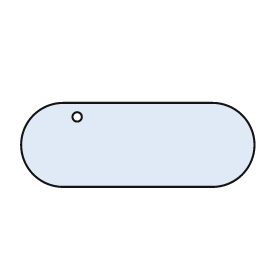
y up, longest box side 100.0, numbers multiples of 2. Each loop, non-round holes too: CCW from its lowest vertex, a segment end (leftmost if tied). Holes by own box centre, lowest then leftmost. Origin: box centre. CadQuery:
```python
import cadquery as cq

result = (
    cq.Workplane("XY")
    .moveTo(-32.0, -18.0)
    .lineTo(32.0, -18.0)
    .threePointArc((50.0, 0.0), (32.0, 18.0))
    .lineTo(-32.0, 18.0)
    .threePointArc((-50.0, 0.0), (-32.0, -18.0))
    .close()
    .moveTo(-26.0, 12.0)
    .circle(2.0)
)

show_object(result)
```